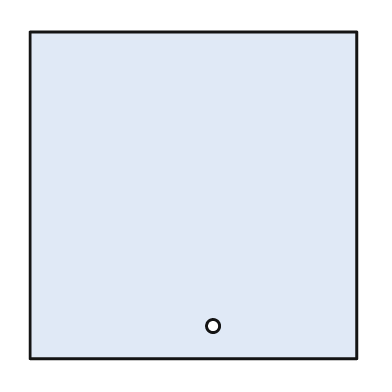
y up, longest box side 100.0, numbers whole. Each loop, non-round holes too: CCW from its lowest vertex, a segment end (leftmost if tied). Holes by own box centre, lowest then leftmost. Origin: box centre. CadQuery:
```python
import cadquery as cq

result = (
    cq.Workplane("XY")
    .moveTo(-50.0, -50.0)
    .lineTo(50.0, -50.0)
    .lineTo(50.0, 50.0)
    .lineTo(-50.0, 50.0)
    .close()
    .moveTo(6.0, -40.0)
    .circle(2.0)
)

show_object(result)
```